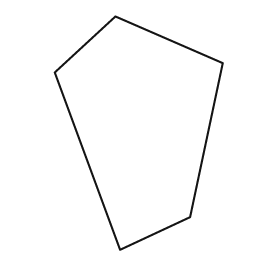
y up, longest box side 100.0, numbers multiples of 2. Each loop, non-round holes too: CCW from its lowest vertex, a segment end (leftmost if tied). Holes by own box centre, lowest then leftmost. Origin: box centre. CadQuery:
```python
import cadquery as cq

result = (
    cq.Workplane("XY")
    .moveTo(-8.0, -50.0)
    .lineTo(22.0, -36.0)
    .lineTo(36.0, 30.0)
    .lineTo(-10.0, 50.0)
    .lineTo(-36.0, 26.0)
    .close()
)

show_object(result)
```